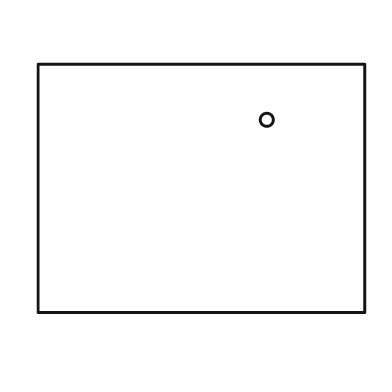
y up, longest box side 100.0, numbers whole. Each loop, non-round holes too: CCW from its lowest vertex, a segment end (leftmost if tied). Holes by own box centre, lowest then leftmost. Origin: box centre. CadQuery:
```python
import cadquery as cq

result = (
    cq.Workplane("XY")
    .moveTo(-50.0, -38.0)
    .lineTo(50.0, -38.0)
    .lineTo(50.0, 38.0)
    .lineTo(-50.0, 38.0)
    .close()
    .moveTo(20.0, 21.0)
    .circle(2.0)
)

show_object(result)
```